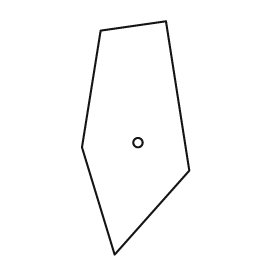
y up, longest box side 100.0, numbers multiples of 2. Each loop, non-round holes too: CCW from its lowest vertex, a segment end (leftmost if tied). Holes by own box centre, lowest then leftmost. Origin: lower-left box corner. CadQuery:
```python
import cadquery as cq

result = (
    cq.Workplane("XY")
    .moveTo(14.0, 0.0)
    .lineTo(46.0, 36.0)
    .lineTo(36.0, 100.0)
    .lineTo(8.0, 96.0)
    .lineTo(0.0, 46.0)
    .close()
    .moveTo(24.0, 48.0)
    .circle(2.0)
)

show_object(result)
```